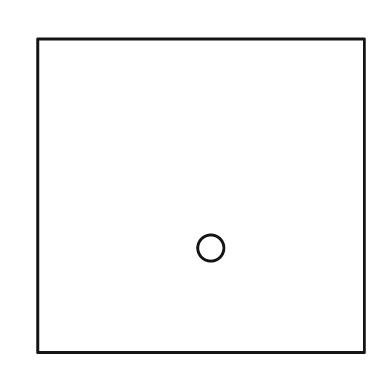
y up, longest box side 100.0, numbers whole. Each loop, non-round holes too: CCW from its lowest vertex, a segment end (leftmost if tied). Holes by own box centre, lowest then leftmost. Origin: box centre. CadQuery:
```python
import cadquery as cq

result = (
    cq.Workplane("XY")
    .moveTo(-50.0, -48.0)
    .lineTo(50.0, -48.0)
    .lineTo(50.0, 48.0)
    .lineTo(-50.0, 48.0)
    .close()
    .moveTo(3.0, -16.0)
    .circle(4.0)
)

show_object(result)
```